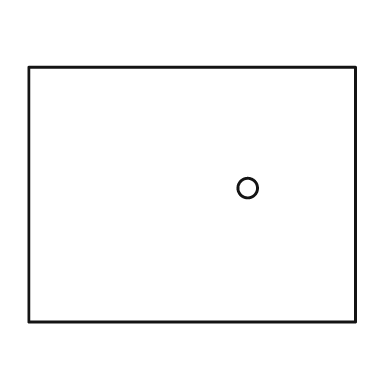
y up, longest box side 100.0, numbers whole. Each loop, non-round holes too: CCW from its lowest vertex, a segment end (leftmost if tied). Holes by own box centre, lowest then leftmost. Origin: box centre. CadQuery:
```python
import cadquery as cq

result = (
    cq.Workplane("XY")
    .moveTo(-50.0, -39.0)
    .lineTo(50.0, -39.0)
    .lineTo(50.0, 39.0)
    .lineTo(-50.0, 39.0)
    .close()
    .moveTo(17.0, 2.0)
    .circle(3.0)
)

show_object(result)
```